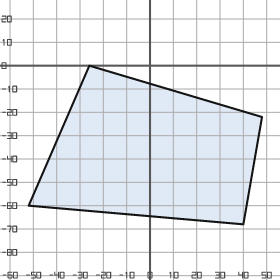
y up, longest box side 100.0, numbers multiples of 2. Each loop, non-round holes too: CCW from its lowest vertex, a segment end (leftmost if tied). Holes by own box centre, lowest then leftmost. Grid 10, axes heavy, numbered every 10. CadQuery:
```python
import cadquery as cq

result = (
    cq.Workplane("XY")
    .moveTo(40.0, -68.0)
    .lineTo(48.0, -22.0)
    .lineTo(-26.0, 0.0)
    .lineTo(-52.0, -60.0)
    .close()
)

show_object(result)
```